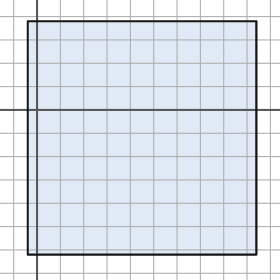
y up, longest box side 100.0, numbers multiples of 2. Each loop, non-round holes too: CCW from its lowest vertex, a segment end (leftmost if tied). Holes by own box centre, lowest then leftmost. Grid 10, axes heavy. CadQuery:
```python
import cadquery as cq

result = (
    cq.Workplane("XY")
    .moveTo(-4.0, -62.0)
    .lineTo(94.0, -62.0)
    .lineTo(94.0, 38.0)
    .lineTo(-4.0, 38.0)
    .close()
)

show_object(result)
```